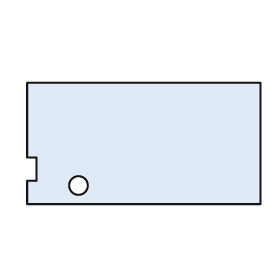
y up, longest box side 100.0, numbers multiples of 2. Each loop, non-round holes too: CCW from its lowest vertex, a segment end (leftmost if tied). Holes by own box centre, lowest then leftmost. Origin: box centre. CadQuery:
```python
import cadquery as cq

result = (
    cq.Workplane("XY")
    .moveTo(-50.0, -26.0)
    .lineTo(50.0, -26.0)
    .lineTo(50.0, 26.0)
    .lineTo(-50.0, 26.0)
    .lineTo(-50.0, -6.0)
    .lineTo(-46.0, -6.0)
    .lineTo(-46.0, -16.0)
    .lineTo(-50.0, -16.0)
    .close()
    .moveTo(-28.0, -18.0)
    .circle(4.0)
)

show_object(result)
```